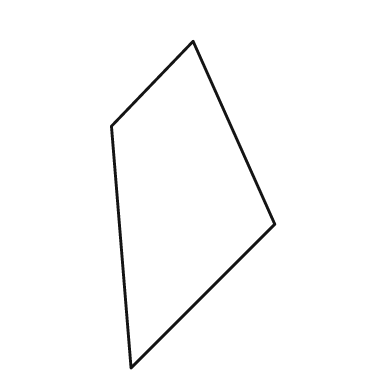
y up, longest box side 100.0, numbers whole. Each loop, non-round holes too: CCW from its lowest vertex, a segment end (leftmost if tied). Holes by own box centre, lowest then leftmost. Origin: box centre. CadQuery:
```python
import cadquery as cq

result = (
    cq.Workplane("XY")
    .moveTo(-19.0, -50.0)
    .lineTo(25.0, -6.0)
    .lineTo(0.0, 50.0)
    .lineTo(-25.0, 24.0)
    .close()
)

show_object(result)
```